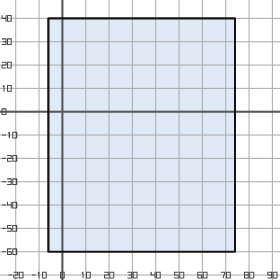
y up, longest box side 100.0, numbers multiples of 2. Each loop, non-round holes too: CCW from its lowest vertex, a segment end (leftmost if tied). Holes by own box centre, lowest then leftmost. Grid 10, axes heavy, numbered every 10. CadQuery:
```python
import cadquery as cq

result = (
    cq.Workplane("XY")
    .moveTo(-6.0, -60.0)
    .lineTo(74.0, -60.0)
    .lineTo(74.0, 40.0)
    .lineTo(-6.0, 40.0)
    .close()
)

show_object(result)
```